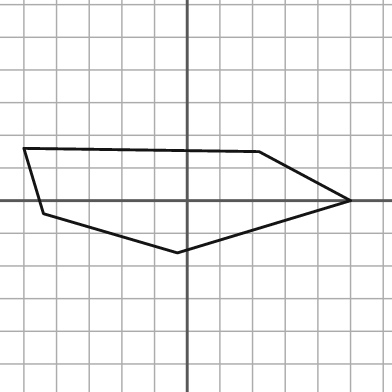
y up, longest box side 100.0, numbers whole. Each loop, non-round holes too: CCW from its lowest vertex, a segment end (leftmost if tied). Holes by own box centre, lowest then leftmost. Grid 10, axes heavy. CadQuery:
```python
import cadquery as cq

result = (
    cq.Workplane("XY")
    .moveTo(-3.0, -16.0)
    .lineTo(50.0, 0.0)
    .lineTo(22.0, 15.0)
    .lineTo(-50.0, 16.0)
    .lineTo(-44.0, -4.0)
    .close()
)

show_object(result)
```